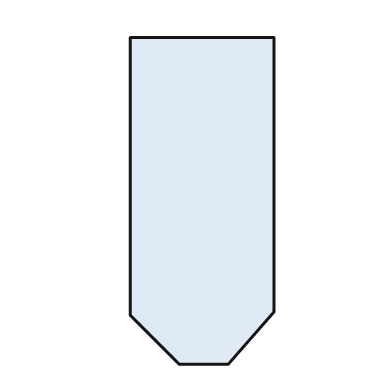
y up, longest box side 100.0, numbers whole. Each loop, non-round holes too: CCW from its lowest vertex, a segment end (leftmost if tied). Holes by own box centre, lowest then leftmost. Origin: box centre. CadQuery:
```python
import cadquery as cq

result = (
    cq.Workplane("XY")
    .moveTo(-7.0, -50.0)
    .lineTo(8.0, -50.0)
    .lineTo(22.0, -34.0)
    .lineTo(22.0, 50.0)
    .lineTo(-22.0, 50.0)
    .lineTo(-22.0, -35.0)
    .close()
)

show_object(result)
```